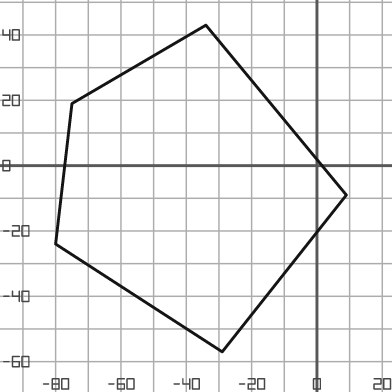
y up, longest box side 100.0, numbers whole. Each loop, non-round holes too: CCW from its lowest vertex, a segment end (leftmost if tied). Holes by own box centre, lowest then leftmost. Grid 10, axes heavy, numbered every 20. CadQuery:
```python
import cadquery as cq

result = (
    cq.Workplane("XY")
    .moveTo(-29.0, -57.0)
    .lineTo(9.0, -9.0)
    .lineTo(-34.0, 43.0)
    .lineTo(-75.0, 19.0)
    .lineTo(-80.0, -24.0)
    .close()
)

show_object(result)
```